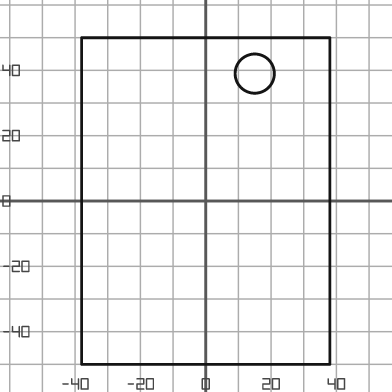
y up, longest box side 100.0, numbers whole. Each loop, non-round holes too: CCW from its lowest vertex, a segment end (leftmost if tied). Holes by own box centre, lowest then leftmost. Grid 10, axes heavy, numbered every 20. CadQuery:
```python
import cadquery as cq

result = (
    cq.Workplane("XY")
    .moveTo(-38.0, -50.0)
    .lineTo(38.0, -50.0)
    .lineTo(38.0, 50.0)
    .lineTo(-38.0, 50.0)
    .close()
    .moveTo(15.0, 39.0)
    .circle(6.0)
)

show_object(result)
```